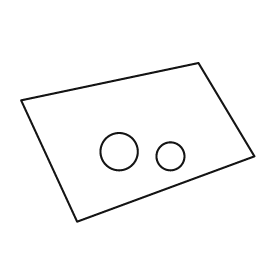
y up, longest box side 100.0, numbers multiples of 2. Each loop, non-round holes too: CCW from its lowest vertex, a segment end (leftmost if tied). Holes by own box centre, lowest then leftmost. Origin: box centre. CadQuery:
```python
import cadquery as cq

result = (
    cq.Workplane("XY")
    .moveTo(-26.0, -34.0)
    .lineTo(50.0, -6.0)
    .lineTo(26.0, 34.0)
    .lineTo(-50.0, 18.0)
    .close()
    .moveTo(14.0, -6.0)
    .circle(6.0)
    .moveTo(-8.0, -4.0)
    .circle(8.0)
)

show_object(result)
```